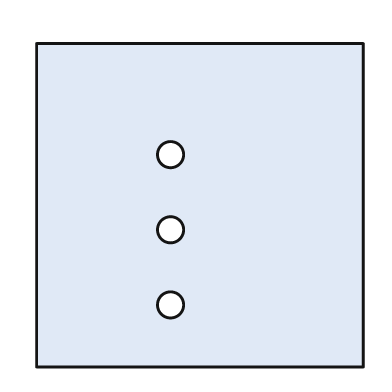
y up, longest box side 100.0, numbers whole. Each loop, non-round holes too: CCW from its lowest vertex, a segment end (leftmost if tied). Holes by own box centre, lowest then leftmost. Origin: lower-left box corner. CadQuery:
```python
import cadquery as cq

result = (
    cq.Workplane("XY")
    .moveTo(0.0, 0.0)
    .lineTo(100.0, 0.0)
    .lineTo(100.0, 99.0)
    .lineTo(0.0, 99.0)
    .close()
    .moveTo(41.0, 19.0)
    .circle(4.0)
    .moveTo(41.0, 42.0)
    .circle(4.0)
    .moveTo(41.0, 65.0)
    .circle(4.0)
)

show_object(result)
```